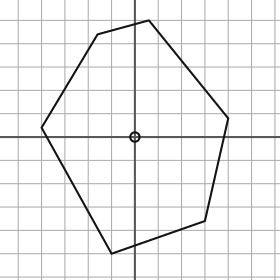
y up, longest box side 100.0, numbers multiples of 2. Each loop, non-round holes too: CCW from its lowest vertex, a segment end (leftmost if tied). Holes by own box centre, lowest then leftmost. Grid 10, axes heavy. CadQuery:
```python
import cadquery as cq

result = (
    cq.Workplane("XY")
    .moveTo(-10.0, -50.0)
    .lineTo(30.0, -36.0)
    .lineTo(40.0, 8.0)
    .lineTo(6.0, 50.0)
    .lineTo(-16.0, 44.0)
    .lineTo(-40.0, 4.0)
    .close()
    .moveTo(0.0, 0.0)
    .circle(2.0)
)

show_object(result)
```